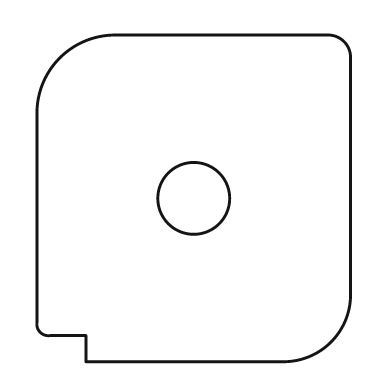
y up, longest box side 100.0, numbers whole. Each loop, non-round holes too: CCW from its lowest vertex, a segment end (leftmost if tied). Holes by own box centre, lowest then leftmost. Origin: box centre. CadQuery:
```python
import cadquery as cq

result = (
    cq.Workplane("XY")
    .moveTo(-33.0, -50.0)
    .lineTo(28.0, -50.0)
    .threePointArc((42.0, -44.0), (48.0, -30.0))
    .lineTo(48.0, 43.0)
    .threePointArc((46.0, 48.0), (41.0, 50.0))
    .lineTo(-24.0, 50.0)
    .threePointArc((-41.0, 43.0), (-48.0, 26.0))
    .lineTo(-48.0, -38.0)
    .threePointArc((-47.0, -41.0), (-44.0, -42.0))
    .lineTo(-33.0, -42.0)
    .close()
    .moveTo(0.0, 0.0)
    .circle(11.0)
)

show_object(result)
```